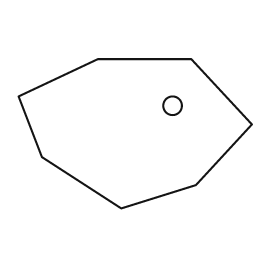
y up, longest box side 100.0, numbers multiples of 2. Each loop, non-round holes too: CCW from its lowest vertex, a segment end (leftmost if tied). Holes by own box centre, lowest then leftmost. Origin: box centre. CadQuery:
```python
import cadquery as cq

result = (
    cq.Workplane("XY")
    .moveTo(-6.0, -32.0)
    .lineTo(26.0, -22.0)
    .lineTo(50.0, 4.0)
    .lineTo(24.0, 32.0)
    .lineTo(-16.0, 32.0)
    .lineTo(-50.0, 16.0)
    .lineTo(-40.0, -10.0)
    .close()
    .moveTo(16.0, 12.0)
    .circle(4.0)
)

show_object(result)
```